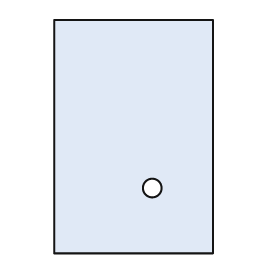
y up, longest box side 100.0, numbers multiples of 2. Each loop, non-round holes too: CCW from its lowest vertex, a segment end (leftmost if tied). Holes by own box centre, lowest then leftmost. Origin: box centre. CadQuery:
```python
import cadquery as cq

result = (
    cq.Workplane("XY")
    .moveTo(-34.0, -50.0)
    .lineTo(34.0, -50.0)
    .lineTo(34.0, 50.0)
    .lineTo(-34.0, 50.0)
    .close()
    .moveTo(8.0, -22.0)
    .circle(4.0)
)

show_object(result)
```